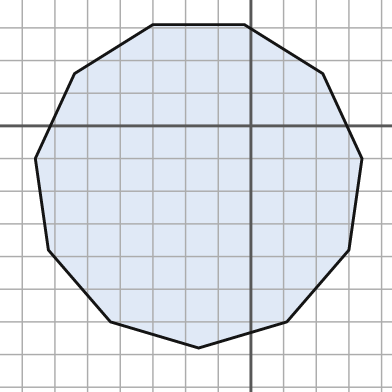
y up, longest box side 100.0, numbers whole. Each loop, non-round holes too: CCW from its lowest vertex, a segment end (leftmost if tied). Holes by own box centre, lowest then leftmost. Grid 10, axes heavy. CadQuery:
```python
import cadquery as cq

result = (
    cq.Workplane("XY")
    .moveTo(-16.0, -68.0)
    .lineTo(11.0, -60.0)
    .lineTo(30.0, -38.0)
    .lineTo(34.0, -10.0)
    .lineTo(22.0, 16.0)
    .lineTo(-2.0, 31.0)
    .lineTo(-30.0, 31.0)
    .lineTo(-54.0, 16.0)
    .lineTo(-66.0, -10.0)
    .lineTo(-62.0, -38.0)
    .lineTo(-43.0, -60.0)
    .close()
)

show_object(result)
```